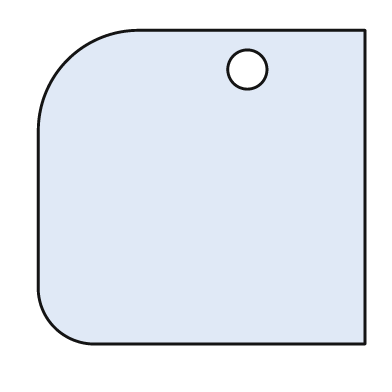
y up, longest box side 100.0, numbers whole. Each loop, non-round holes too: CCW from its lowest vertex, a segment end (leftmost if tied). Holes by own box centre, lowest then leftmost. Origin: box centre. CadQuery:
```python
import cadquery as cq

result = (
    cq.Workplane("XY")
    .moveTo(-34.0, -48.0)
    .lineTo(50.0, -48.0)
    .lineTo(50.0, 48.0)
    .lineTo(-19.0, 48.0)
    .threePointArc((-41.0, 39.0), (-50.0, 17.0))
    .lineTo(-50.0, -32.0)
    .threePointArc((-45.0, -43.0), (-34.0, -48.0))
    .close()
    .moveTo(14.0, 36.0)
    .circle(6.0)
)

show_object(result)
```